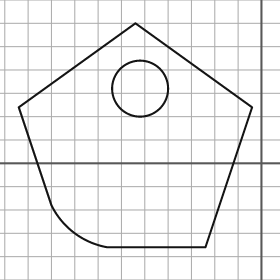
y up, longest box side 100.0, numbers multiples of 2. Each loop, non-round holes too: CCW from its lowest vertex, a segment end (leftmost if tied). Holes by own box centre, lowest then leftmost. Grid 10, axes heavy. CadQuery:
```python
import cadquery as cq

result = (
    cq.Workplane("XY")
    .moveTo(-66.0, -36.0)
    .lineTo(-24.0, -36.0)
    .lineTo(-4.0, 24.0)
    .lineTo(-54.0, 60.0)
    .lineTo(-104.0, 24.0)
    .lineTo(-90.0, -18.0)
    .threePointArc((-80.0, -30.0), (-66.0, -36.0))
    .close()
    .moveTo(-52.0, 32.0)
    .circle(12.0)
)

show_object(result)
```